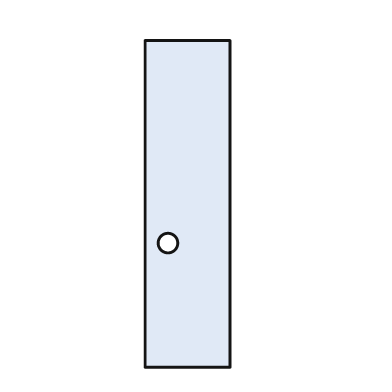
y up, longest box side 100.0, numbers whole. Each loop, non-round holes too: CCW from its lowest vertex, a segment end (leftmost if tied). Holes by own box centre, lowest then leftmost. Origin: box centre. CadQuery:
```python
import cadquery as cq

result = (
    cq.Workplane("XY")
    .moveTo(-13.0, -50.0)
    .lineTo(13.0, -50.0)
    .lineTo(13.0, 50.0)
    .lineTo(-13.0, 50.0)
    .close()
    .moveTo(-6.0, -12.0)
    .circle(3.0)
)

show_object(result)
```